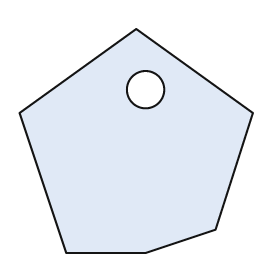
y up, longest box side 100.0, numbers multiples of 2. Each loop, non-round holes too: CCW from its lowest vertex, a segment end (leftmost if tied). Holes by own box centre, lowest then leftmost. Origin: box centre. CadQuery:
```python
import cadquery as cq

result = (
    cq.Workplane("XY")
    .moveTo(-30.0, -48.0)
    .lineTo(4.0, -48.0)
    .lineTo(34.0, -38.0)
    .lineTo(50.0, 12.0)
    .lineTo(0.0, 48.0)
    .lineTo(-50.0, 12.0)
    .close()
    .moveTo(4.0, 22.0)
    .circle(8.0)
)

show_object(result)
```